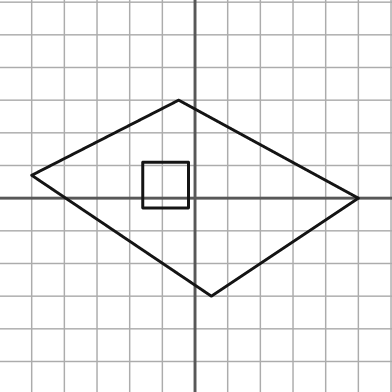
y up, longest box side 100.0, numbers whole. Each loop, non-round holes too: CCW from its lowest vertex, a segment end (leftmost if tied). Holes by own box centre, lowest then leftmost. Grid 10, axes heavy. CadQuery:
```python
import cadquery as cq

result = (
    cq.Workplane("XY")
    .moveTo(5.0, -30.0)
    .lineTo(50.0, 0.0)
    .lineTo(-5.0, 30.0)
    .lineTo(-50.0, 7.0)
    .close()
    .moveTo(-16.0, -3.0)
    .lineTo(-2.0, -3.0)
    .lineTo(-2.0, 11.0)
    .lineTo(-16.0, 11.0)
    .close()
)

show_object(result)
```